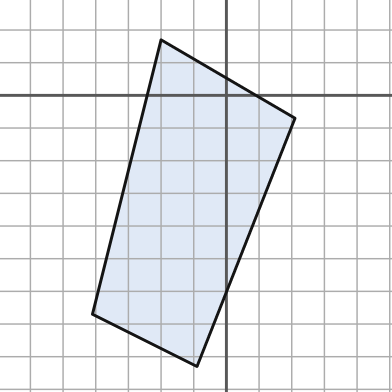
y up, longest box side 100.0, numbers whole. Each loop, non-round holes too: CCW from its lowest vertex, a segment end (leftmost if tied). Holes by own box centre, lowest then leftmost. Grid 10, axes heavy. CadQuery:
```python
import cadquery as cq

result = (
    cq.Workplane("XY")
    .moveTo(-9.0, -83.0)
    .lineTo(21.0, -7.0)
    .lineTo(-20.0, 17.0)
    .lineTo(-41.0, -67.0)
    .close()
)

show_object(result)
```